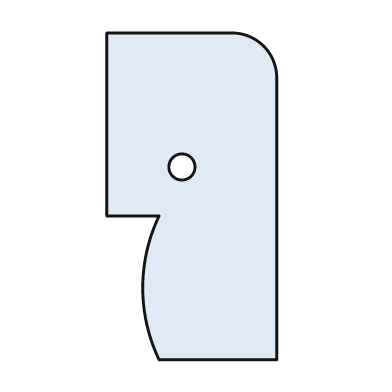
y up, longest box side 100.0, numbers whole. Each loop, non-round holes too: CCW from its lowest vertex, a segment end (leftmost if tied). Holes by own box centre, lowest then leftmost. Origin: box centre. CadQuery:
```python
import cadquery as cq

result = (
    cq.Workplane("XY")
    .moveTo(-10.0, -50.0)
    .lineTo(26.0, -50.0)
    .lineTo(26.0, 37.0)
    .threePointArc((22.0, 46.0), (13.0, 50.0))
    .lineTo(-26.0, 50.0)
    .lineTo(-26.0, -6.0)
    .lineTo(-10.0, -6.0)
    .threePointArc((-15.0, -28.0), (-10.0, -50.0))
    .close()
    .moveTo(-3.0, 9.0)
    .circle(4.0)
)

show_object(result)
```